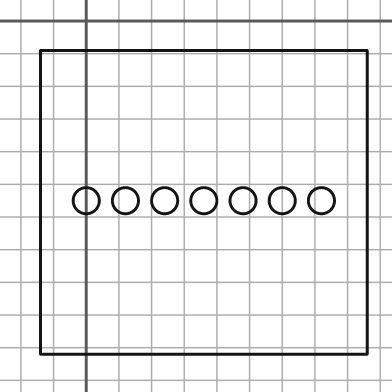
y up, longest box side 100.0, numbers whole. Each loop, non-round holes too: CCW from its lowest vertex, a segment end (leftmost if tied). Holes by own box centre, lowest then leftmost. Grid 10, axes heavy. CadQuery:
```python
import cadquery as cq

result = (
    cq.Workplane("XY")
    .moveTo(-14.0, -102.0)
    .lineTo(86.0, -102.0)
    .lineTo(86.0, -9.0)
    .lineTo(-14.0, -9.0)
    .close()
    .moveTo(0.0, -55.0)
    .circle(4.0)
    .moveTo(12.0, -55.0)
    .circle(4.0)
    .moveTo(24.0, -55.0)
    .circle(4.0)
    .moveTo(36.0, -55.0)
    .circle(4.0)
    .moveTo(48.0, -55.0)
    .circle(4.0)
    .moveTo(60.0, -55.0)
    .circle(4.0)
    .moveTo(72.0, -55.0)
    .circle(4.0)
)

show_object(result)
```